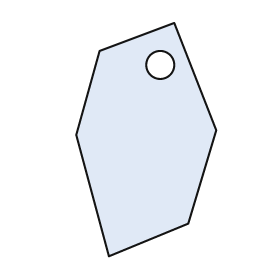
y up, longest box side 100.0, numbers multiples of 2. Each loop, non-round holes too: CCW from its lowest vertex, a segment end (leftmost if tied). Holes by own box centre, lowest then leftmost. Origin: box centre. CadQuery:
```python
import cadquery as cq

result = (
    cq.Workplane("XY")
    .moveTo(-16.0, -50.0)
    .lineTo(18.0, -36.0)
    .lineTo(30.0, 4.0)
    .lineTo(12.0, 50.0)
    .lineTo(-20.0, 38.0)
    .lineTo(-30.0, 2.0)
    .close()
    .moveTo(6.0, 32.0)
    .circle(6.0)
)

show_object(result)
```